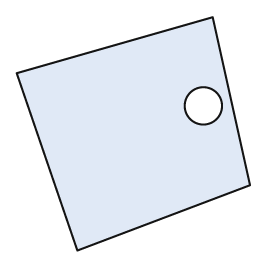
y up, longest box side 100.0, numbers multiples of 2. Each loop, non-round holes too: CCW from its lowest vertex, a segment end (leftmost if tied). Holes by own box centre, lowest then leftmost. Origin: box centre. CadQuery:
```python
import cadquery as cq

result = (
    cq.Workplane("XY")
    .moveTo(-24.0, -50.0)
    .lineTo(50.0, -22.0)
    .lineTo(34.0, 50.0)
    .lineTo(-50.0, 26.0)
    .close()
    .moveTo(30.0, 12.0)
    .circle(8.0)
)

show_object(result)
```